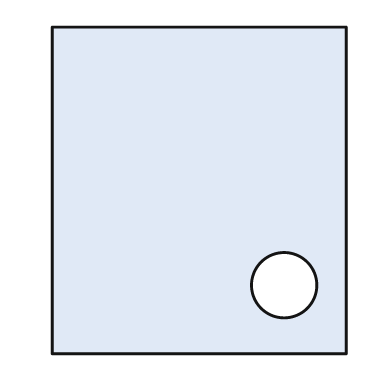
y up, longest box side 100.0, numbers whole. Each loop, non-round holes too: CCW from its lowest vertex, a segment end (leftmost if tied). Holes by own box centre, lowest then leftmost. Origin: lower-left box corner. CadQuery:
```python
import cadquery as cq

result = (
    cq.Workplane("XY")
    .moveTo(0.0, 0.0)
    .lineTo(90.0, 0.0)
    .lineTo(90.0, 100.0)
    .lineTo(0.0, 100.0)
    .close()
    .moveTo(71.0, 21.0)
    .circle(10.0)
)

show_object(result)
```